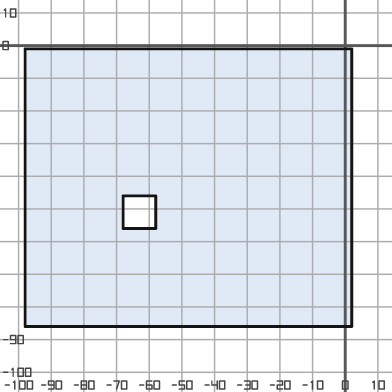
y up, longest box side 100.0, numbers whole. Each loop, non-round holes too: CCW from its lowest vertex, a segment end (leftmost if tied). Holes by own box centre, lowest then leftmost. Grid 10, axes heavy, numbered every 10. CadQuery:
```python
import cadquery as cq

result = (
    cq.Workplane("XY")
    .moveTo(-98.0, -86.0)
    .lineTo(2.0, -86.0)
    .lineTo(2.0, -1.0)
    .lineTo(-98.0, -1.0)
    .close()
    .moveTo(-68.0, -56.0)
    .lineTo(-58.0, -56.0)
    .lineTo(-58.0, -46.0)
    .lineTo(-68.0, -46.0)
    .close()
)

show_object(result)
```